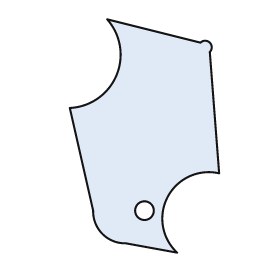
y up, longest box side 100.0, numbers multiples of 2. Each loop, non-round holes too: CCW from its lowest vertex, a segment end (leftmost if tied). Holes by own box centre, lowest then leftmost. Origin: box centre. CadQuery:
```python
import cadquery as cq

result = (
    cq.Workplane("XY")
    .moveTo(14.0, -50.0)
    .threePointArc((10.0, -26.0), (32.0, -16.0))
    .lineTo(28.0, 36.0)
    .threePointArc((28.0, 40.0), (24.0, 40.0))
    .lineTo(-16.0, 50.0)
    .threePointArc((-12.0, 26.0), (-32.0, 12.0))
    .lineTo(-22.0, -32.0)
    .threePointArc((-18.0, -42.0), (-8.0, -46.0))
    .close()
    .moveTo(0.0, -32.0)
    .circle(4.0)
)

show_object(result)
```